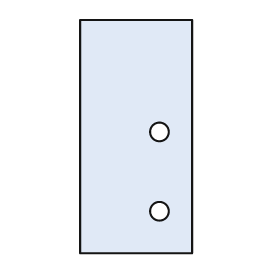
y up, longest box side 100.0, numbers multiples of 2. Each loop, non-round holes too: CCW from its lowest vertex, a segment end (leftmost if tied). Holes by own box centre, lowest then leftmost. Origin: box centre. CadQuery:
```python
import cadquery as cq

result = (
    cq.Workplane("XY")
    .moveTo(-24.0, -50.0)
    .lineTo(24.0, -50.0)
    .lineTo(24.0, 50.0)
    .lineTo(-24.0, 50.0)
    .close()
    .moveTo(10.0, -32.0)
    .circle(4.0)
    .moveTo(10.0, 2.0)
    .circle(4.0)
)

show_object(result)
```